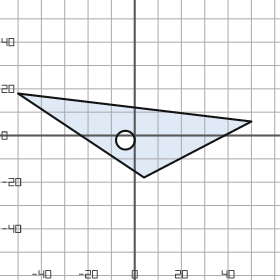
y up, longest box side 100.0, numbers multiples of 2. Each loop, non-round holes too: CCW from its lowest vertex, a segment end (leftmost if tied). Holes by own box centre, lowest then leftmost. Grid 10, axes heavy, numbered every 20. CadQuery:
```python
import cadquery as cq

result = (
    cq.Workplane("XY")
    .moveTo(4.0, -18.0)
    .lineTo(50.0, 6.0)
    .lineTo(-50.0, 18.0)
    .close()
    .moveTo(-4.0, -2.0)
    .circle(4.0)
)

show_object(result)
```